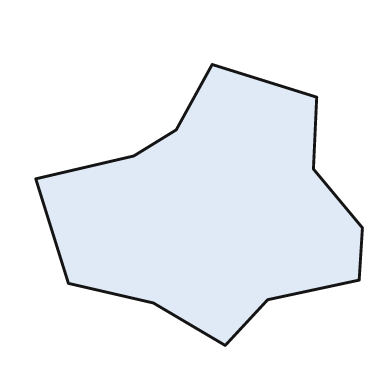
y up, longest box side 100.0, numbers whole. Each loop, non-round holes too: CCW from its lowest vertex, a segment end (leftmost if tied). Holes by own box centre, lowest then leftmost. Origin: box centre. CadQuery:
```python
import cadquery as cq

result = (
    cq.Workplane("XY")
    .moveTo(8.0, -43.0)
    .lineTo(21.0, -29.0)
    .lineTo(49.0, -23.0)
    .lineTo(50.0, -7.0)
    .lineTo(35.0, 11.0)
    .lineTo(36.0, 33.0)
    .lineTo(4.0, 43.0)
    .lineTo(-7.0, 23.0)
    .lineTo(-20.0, 15.0)
    .lineTo(-50.0, 8.0)
    .lineTo(-40.0, -24.0)
    .lineTo(-14.0, -30.0)
    .close()
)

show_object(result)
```